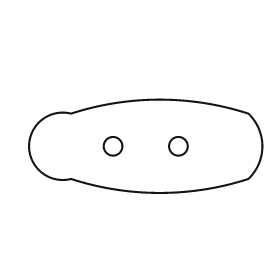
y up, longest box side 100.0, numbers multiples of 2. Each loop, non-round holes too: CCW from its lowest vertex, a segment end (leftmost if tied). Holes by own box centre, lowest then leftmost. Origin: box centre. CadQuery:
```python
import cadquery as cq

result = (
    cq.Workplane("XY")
    .moveTo(-32.0, -14.0)
    .threePointArc((6.0, -20.0), (44.0, -14.0))
    .threePointArc((50.0, 0.0), (44.0, 14.0))
    .threePointArc((6.0, 20.0), (-32.0, 14.0))
    .threePointArc((-50.0, 0.0), (-32.0, -14.0))
    .close()
    .moveTo(-14.0, 0.0)
    .circle(4.0)
    .moveTo(14.0, 0.0)
    .circle(4.0)
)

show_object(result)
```